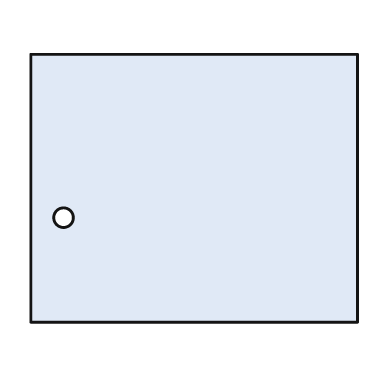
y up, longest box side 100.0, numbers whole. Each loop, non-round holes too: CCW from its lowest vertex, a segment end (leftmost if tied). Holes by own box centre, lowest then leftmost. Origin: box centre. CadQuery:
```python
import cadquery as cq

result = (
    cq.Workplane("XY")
    .moveTo(-50.0, -41.0)
    .lineTo(50.0, -41.0)
    .lineTo(50.0, 41.0)
    .lineTo(-50.0, 41.0)
    .close()
    .moveTo(-40.0, -9.0)
    .circle(3.0)
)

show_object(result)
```